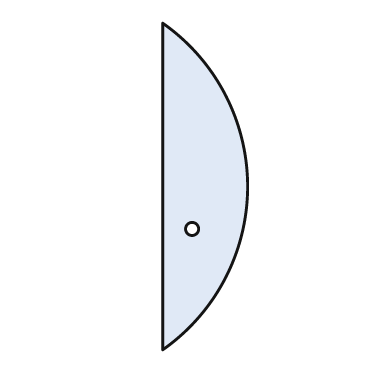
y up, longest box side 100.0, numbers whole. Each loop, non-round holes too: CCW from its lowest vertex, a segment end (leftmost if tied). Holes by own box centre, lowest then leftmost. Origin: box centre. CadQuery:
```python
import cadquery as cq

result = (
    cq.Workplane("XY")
    .moveTo(-13.0, -50.0)
    .threePointArc((13.0, 0.0), (-13.0, 50.0))
    .close()
    .moveTo(-4.0, -13.0)
    .circle(2.0)
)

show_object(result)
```